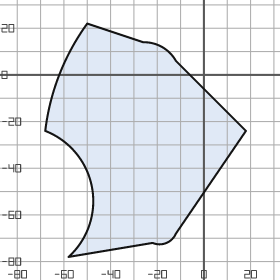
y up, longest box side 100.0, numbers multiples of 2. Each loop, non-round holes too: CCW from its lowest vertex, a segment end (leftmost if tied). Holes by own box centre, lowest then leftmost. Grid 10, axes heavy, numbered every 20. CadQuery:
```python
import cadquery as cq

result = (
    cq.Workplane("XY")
    .moveTo(-58.0, -78.0)
    .lineTo(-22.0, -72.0)
    .threePointArc((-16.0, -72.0), (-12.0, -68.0))
    .lineTo(18.0, -24.0)
    .lineTo(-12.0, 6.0)
    .threePointArc((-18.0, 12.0), (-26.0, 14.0))
    .lineTo(-50.0, 22.0)
    .threePointArc((-62.0, 0.0), (-68.0, -24.0))
    .threePointArc((-48.0, -48.0), (-58.0, -78.0))
    .close()
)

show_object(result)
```